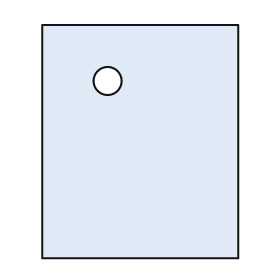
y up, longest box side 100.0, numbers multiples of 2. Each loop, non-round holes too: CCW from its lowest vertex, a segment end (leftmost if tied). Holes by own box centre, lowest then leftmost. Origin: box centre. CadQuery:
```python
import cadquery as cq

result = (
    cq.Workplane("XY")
    .moveTo(-42.0, -50.0)
    .lineTo(42.0, -50.0)
    .lineTo(42.0, 50.0)
    .lineTo(-42.0, 50.0)
    .close()
    .moveTo(-14.0, 26.0)
    .circle(6.0)
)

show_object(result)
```